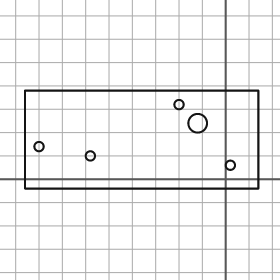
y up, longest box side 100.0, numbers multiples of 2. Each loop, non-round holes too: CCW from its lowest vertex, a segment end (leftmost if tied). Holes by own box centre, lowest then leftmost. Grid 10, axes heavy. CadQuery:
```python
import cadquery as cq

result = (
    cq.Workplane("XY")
    .moveTo(-86.0, -4.0)
    .lineTo(14.0, -4.0)
    .lineTo(14.0, 38.0)
    .lineTo(-86.0, 38.0)
    .close()
    .moveTo(2.0, 6.0)
    .circle(2.0)
    .moveTo(-58.0, 10.0)
    .circle(2.0)
    .moveTo(-80.0, 14.0)
    .circle(2.0)
    .moveTo(-12.0, 24.0)
    .circle(4.0)
    .moveTo(-20.0, 32.0)
    .circle(2.0)
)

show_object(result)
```